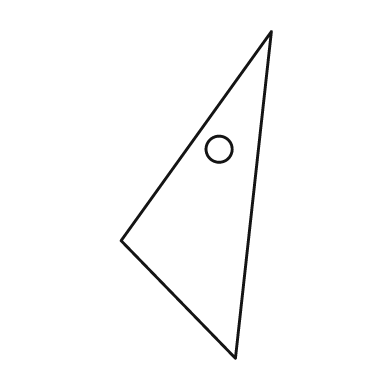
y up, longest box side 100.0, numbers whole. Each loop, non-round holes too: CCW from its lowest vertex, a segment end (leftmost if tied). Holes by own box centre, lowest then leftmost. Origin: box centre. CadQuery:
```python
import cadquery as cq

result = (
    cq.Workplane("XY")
    .moveTo(12.0, -50.0)
    .lineTo(23.0, 50.0)
    .lineTo(-23.0, -14.0)
    .close()
    .moveTo(7.0, 14.0)
    .circle(4.0)
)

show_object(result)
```